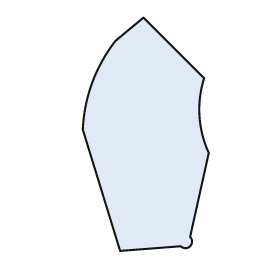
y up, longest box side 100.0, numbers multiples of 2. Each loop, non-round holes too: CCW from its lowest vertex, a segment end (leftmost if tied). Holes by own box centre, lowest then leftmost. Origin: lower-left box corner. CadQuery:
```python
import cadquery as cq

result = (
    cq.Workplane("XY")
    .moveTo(16.0, 0.0)
    .lineTo(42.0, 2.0)
    .threePointArc((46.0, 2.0), (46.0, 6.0))
    .lineTo(54.0, 42.0)
    .threePointArc((50.0, 58.0), (52.0, 74.0))
    .lineTo(26.0, 100.0)
    .lineTo(14.0, 90.0)
    .threePointArc((4.0, 72.0), (0.0, 52.0))
    .close()
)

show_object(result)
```